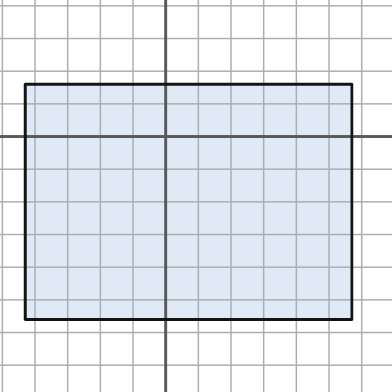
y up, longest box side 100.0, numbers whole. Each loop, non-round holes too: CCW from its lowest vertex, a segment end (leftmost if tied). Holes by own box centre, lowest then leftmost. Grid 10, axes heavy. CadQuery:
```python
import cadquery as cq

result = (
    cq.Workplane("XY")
    .moveTo(-43.0, -56.0)
    .lineTo(57.0, -56.0)
    .lineTo(57.0, 16.0)
    .lineTo(-43.0, 16.0)
    .close()
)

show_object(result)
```